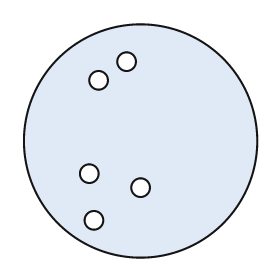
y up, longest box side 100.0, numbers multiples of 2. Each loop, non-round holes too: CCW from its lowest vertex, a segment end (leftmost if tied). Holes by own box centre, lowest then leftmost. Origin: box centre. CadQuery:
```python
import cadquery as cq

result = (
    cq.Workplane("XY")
    .moveTo(0.0, 0.0)
    .circle(50.0)
    .moveTo(-20.0, -34.0)
    .circle(4.0)
    .moveTo(0.0, -20.0)
    .circle(4.0)
    .moveTo(-22.0, -14.0)
    .circle(4.0)
    .moveTo(-18.0, 26.0)
    .circle(4.0)
    .moveTo(-6.0, 34.0)
    .circle(4.0)
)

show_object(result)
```